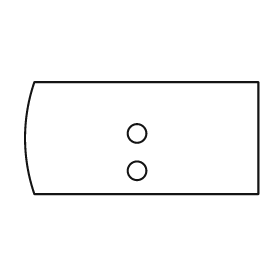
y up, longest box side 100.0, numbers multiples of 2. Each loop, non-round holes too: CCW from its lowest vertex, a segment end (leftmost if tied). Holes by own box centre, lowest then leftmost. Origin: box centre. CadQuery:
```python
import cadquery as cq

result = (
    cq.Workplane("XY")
    .moveTo(-46.0, -24.0)
    .lineTo(50.0, -24.0)
    .lineTo(50.0, 24.0)
    .lineTo(-46.0, 24.0)
    .threePointArc((-50.0, 0.0), (-46.0, -24.0))
    .close()
    .moveTo(-2.0, -14.0)
    .circle(4.0)
    .moveTo(-2.0, 2.0)
    .circle(4.0)
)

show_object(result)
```